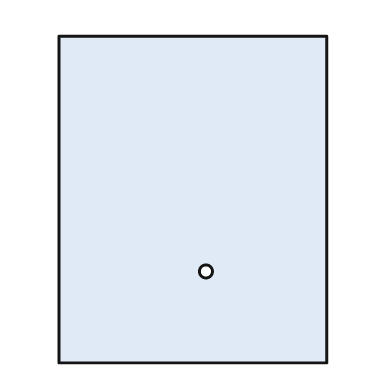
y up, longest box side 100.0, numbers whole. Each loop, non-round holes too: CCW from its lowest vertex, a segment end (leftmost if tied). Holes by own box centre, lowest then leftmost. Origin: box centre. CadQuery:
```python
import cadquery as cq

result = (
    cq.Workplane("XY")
    .moveTo(-41.0, -50.0)
    .lineTo(41.0, -50.0)
    .lineTo(41.0, 50.0)
    .lineTo(-41.0, 50.0)
    .close()
    .moveTo(4.0, -22.0)
    .circle(2.0)
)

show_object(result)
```